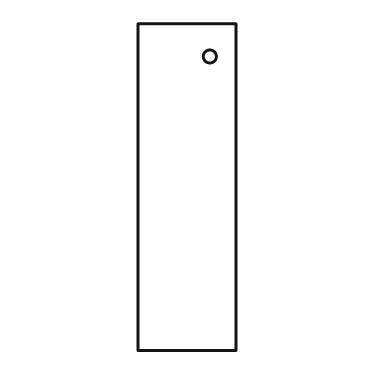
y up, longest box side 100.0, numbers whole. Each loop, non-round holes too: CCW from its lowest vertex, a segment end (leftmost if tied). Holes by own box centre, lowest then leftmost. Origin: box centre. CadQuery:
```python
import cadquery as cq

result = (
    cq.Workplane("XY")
    .moveTo(-15.0, -50.0)
    .lineTo(15.0, -50.0)
    .lineTo(15.0, 50.0)
    .lineTo(-15.0, 50.0)
    .close()
    .moveTo(7.0, 40.0)
    .circle(2.0)
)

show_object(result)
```